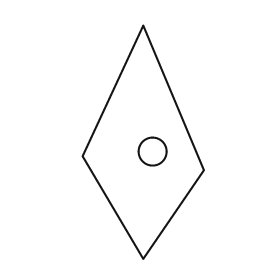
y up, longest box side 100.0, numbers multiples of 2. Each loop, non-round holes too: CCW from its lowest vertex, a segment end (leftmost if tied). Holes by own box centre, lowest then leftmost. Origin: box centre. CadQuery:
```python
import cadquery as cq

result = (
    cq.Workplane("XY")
    .moveTo(0.0, -50.0)
    .lineTo(26.0, -12.0)
    .lineTo(0.0, 50.0)
    .lineTo(-26.0, -6.0)
    .close()
    .moveTo(4.0, -4.0)
    .circle(6.0)
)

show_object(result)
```